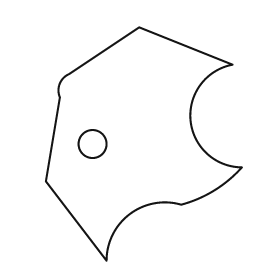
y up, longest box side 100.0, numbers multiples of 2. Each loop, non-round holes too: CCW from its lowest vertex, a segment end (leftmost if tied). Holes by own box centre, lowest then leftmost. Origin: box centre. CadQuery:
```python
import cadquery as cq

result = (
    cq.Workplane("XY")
    .moveTo(-16.0, -50.0)
    .threePointArc((-6.0, -30.0), (16.0, -26.0))
    .threePointArc((30.0, -20.0), (42.0, -10.0))
    .threePointArc((20.0, 10.0), (38.0, 34.0))
    .lineTo(-2.0, 50.0)
    .lineTo(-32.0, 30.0)
    .threePointArc((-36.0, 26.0), (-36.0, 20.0))
    .lineTo(-42.0, -16.0)
    .close()
    .moveTo(-22.0, 0.0)
    .circle(6.0)
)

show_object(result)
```